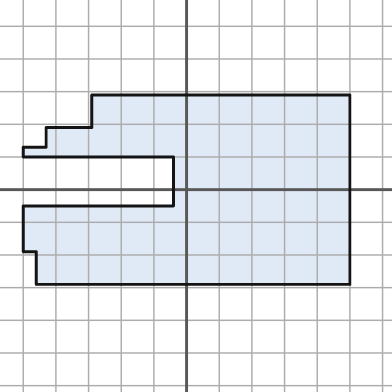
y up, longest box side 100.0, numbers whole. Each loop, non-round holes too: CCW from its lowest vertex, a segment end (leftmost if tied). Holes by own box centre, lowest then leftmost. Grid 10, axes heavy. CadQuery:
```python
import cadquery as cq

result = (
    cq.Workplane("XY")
    .moveTo(-46.0, -29.0)
    .lineTo(50.0, -29.0)
    .lineTo(50.0, 29.0)
    .lineTo(-29.0, 29.0)
    .lineTo(-29.0, 19.0)
    .lineTo(-43.0, 19.0)
    .lineTo(-43.0, 13.0)
    .lineTo(-50.0, 13.0)
    .lineTo(-50.0, 10.0)
    .lineTo(-4.0, 10.0)
    .lineTo(-4.0, -5.0)
    .lineTo(-50.0, -5.0)
    .lineTo(-50.0, -19.0)
    .lineTo(-46.0, -19.0)
    .close()
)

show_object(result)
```